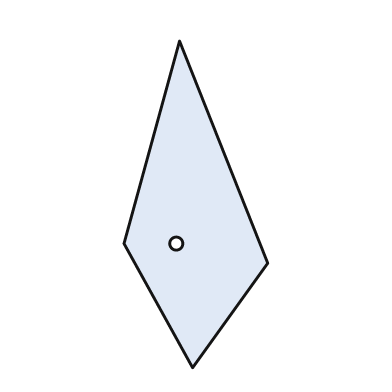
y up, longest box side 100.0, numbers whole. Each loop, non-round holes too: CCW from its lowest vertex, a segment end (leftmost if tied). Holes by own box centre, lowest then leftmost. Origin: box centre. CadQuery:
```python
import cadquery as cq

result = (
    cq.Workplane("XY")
    .moveTo(-1.0, -50.0)
    .lineTo(22.0, -18.0)
    .lineTo(-5.0, 50.0)
    .lineTo(-22.0, -12.0)
    .close()
    .moveTo(-6.0, -12.0)
    .circle(2.0)
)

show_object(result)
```